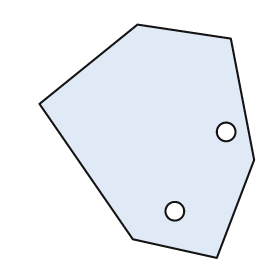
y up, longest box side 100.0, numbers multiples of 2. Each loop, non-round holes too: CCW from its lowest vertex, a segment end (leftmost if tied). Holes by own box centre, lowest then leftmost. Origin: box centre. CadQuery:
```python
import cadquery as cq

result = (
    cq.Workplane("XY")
    .moveTo(30.0, -50.0)
    .lineTo(46.0, -8.0)
    .lineTo(36.0, 44.0)
    .lineTo(-4.0, 50.0)
    .lineTo(-46.0, 16.0)
    .lineTo(-6.0, -42.0)
    .close()
    .moveTo(12.0, -30.0)
    .circle(4.0)
    .moveTo(34.0, 4.0)
    .circle(4.0)
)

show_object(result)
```